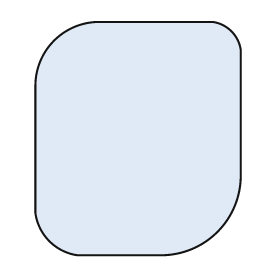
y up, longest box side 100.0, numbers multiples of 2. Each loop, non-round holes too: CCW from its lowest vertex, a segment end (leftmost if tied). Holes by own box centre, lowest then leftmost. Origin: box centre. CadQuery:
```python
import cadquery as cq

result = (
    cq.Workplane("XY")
    .moveTo(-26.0, -50.0)
    .lineTo(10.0, -50.0)
    .threePointArc((34.0, -40.0), (44.0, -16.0))
    .lineTo(44.0, 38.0)
    .threePointArc((40.0, 46.0), (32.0, 50.0))
    .lineTo(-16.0, 50.0)
    .threePointArc((-36.0, 42.0), (-44.0, 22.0))
    .lineTo(-44.0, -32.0)
    .threePointArc((-38.0, -44.0), (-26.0, -50.0))
    .close()
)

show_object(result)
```